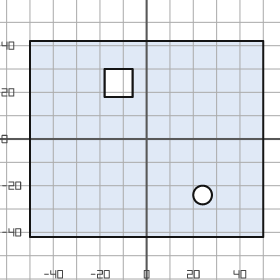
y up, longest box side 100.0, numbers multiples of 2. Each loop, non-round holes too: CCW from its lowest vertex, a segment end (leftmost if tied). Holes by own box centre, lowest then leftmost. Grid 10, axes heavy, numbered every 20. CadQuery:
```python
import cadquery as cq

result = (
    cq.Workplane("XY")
    .moveTo(-50.0, -42.0)
    .lineTo(50.0, -42.0)
    .lineTo(50.0, 42.0)
    .lineTo(-50.0, 42.0)
    .close()
    .moveTo(24.0, -24.0)
    .circle(4.0)
    .moveTo(-18.0, 18.0)
    .lineTo(-6.0, 18.0)
    .lineTo(-6.0, 30.0)
    .lineTo(-18.0, 30.0)
    .close()
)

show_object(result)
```